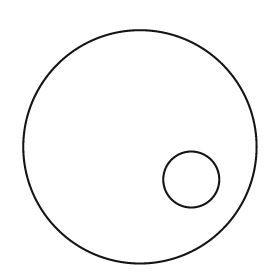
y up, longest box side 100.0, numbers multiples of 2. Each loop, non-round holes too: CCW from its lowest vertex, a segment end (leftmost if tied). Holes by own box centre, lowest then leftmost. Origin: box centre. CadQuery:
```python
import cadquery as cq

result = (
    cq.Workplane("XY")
    .moveTo(0.0, 0.0)
    .circle(50.0)
    .moveTo(22.0, -14.0)
    .circle(12.0)
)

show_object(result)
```